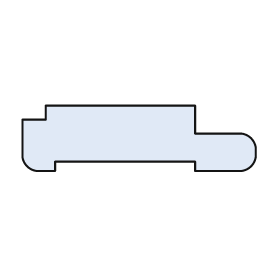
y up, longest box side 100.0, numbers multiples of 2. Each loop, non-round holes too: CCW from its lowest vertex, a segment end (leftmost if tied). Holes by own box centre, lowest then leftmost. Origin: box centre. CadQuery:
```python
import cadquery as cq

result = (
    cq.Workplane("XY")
    .moveTo(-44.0, -14.0)
    .lineTo(-36.0, -14.0)
    .lineTo(-36.0, -10.0)
    .lineTo(24.0, -10.0)
    .lineTo(24.0, -14.0)
    .lineTo(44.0, -14.0)
    .threePointArc((48.0, -12.0), (50.0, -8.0))
    .lineTo(50.0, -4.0)
    .threePointArc((48.0, 0.0), (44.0, 2.0))
    .lineTo(24.0, 2.0)
    .lineTo(24.0, 14.0)
    .lineTo(-40.0, 14.0)
    .lineTo(-40.0, 8.0)
    .lineTo(-50.0, 8.0)
    .lineTo(-50.0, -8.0)
    .threePointArc((-48.0, -12.0), (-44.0, -14.0))
    .close()
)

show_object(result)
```